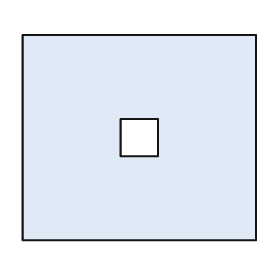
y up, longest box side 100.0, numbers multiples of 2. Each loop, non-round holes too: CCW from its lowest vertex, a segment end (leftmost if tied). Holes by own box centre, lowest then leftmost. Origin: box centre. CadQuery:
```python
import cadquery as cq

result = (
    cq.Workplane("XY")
    .moveTo(-50.0, -44.0)
    .lineTo(50.0, -44.0)
    .lineTo(50.0, 44.0)
    .lineTo(-50.0, 44.0)
    .close()
    .moveTo(-8.0, -8.0)
    .lineTo(8.0, -8.0)
    .lineTo(8.0, 8.0)
    .lineTo(-8.0, 8.0)
    .close()
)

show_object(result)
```